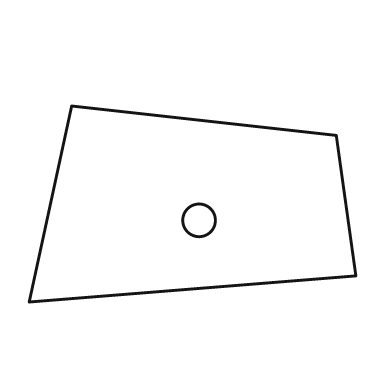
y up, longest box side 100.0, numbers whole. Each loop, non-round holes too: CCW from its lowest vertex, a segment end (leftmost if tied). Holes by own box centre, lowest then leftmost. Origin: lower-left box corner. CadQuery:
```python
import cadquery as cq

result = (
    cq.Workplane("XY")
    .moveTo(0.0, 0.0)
    .lineTo(100.0, 8.0)
    .lineTo(94.0, 51.0)
    .lineTo(13.0, 60.0)
    .close()
    .moveTo(52.0, 25.0)
    .circle(5.0)
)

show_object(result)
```